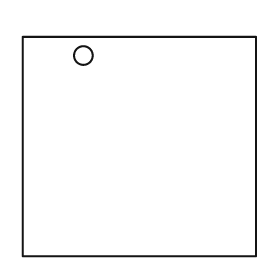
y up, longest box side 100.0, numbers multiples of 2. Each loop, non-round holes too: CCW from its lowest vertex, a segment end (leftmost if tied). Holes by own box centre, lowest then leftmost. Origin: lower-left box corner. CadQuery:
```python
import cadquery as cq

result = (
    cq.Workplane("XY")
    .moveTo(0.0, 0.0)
    .lineTo(100.0, 0.0)
    .lineTo(100.0, 94.0)
    .lineTo(0.0, 94.0)
    .close()
    .moveTo(26.0, 86.0)
    .circle(4.0)
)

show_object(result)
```